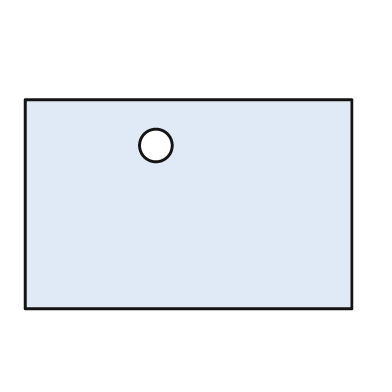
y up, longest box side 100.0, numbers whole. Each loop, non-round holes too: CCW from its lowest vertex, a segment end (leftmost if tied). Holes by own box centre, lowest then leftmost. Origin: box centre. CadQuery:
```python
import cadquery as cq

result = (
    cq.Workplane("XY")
    .moveTo(-50.0, -32.0)
    .lineTo(50.0, -32.0)
    .lineTo(50.0, 32.0)
    .lineTo(-50.0, 32.0)
    .close()
    .moveTo(-10.0, 18.0)
    .circle(5.0)
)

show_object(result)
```